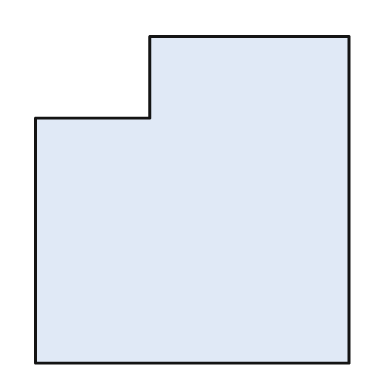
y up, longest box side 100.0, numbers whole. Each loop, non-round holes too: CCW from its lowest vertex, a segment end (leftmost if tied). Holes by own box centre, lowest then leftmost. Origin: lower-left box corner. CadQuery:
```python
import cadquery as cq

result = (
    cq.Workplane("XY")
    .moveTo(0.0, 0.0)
    .lineTo(96.0, 0.0)
    .lineTo(96.0, 100.0)
    .lineTo(35.0, 100.0)
    .lineTo(35.0, 75.0)
    .lineTo(0.0, 75.0)
    .close()
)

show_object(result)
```